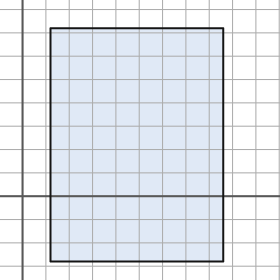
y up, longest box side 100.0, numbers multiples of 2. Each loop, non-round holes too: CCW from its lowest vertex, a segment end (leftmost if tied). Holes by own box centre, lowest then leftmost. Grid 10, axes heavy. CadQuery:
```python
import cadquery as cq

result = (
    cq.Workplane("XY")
    .moveTo(12.0, -28.0)
    .lineTo(86.0, -28.0)
    .lineTo(86.0, 72.0)
    .lineTo(12.0, 72.0)
    .close()
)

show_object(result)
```